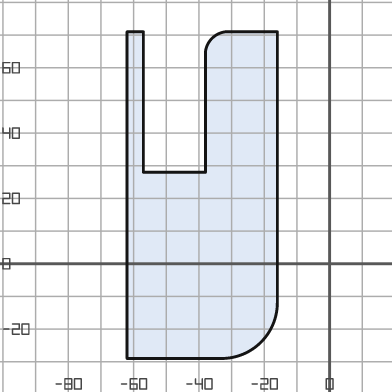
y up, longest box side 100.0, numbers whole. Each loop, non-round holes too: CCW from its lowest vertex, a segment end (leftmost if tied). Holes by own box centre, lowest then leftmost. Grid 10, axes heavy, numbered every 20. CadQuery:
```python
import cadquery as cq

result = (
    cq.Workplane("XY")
    .moveTo(-62.0, -29.0)
    .lineTo(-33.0, -29.0)
    .threePointArc((-21.0, -24.0), (-16.0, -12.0))
    .lineTo(-16.0, 71.0)
    .lineTo(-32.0, 71.0)
    .threePointArc((-36.0, 69.0), (-38.0, 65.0))
    .lineTo(-38.0, 28.0)
    .lineTo(-57.0, 28.0)
    .lineTo(-57.0, 71.0)
    .lineTo(-62.0, 71.0)
    .close()
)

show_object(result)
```